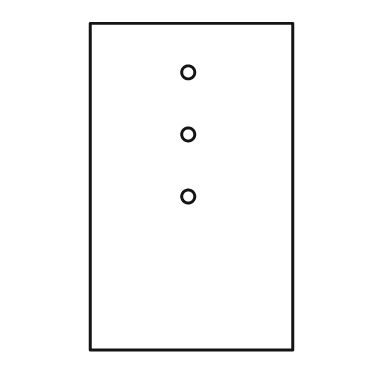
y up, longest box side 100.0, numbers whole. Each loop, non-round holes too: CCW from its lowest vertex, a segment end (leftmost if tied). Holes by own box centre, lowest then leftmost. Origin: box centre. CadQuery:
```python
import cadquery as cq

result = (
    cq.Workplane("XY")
    .moveTo(-31.0, -50.0)
    .lineTo(31.0, -50.0)
    .lineTo(31.0, 50.0)
    .lineTo(-31.0, 50.0)
    .close()
    .moveTo(-1.0, -3.0)
    .circle(2.0)
    .moveTo(-1.0, 16.0)
    .circle(2.0)
    .moveTo(-1.0, 35.0)
    .circle(2.0)
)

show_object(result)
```